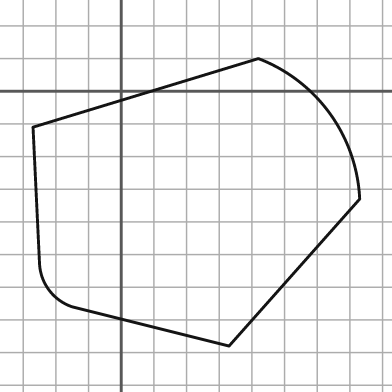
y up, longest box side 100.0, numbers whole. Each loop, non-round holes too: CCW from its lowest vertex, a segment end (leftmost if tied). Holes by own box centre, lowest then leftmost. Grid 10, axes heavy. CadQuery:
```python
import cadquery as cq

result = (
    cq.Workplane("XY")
    .moveTo(33.0, -78.0)
    .lineTo(73.0, -33.0)
    .threePointArc((64.0, -7.0), (42.0, 10.0))
    .lineTo(-27.0, -11.0)
    .lineTo(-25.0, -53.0)
    .threePointArc((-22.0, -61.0), (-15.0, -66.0))
    .close()
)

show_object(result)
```